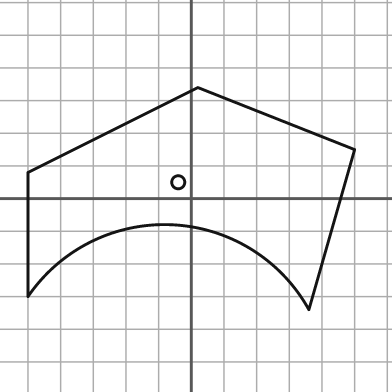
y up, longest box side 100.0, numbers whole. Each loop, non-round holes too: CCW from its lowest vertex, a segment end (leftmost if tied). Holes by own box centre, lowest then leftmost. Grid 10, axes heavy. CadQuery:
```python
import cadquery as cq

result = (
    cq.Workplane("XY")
    .moveTo(36.0, -34.0)
    .lineTo(50.0, 15.0)
    .lineTo(2.0, 34.0)
    .lineTo(-50.0, 8.0)
    .lineTo(-50.0, -30.0)
    .threePointArc((-6.0, -8.0), (36.0, -34.0))
    .close()
    .moveTo(-4.0, 5.0)
    .circle(2.0)
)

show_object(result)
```